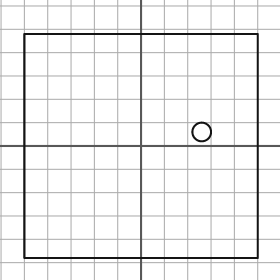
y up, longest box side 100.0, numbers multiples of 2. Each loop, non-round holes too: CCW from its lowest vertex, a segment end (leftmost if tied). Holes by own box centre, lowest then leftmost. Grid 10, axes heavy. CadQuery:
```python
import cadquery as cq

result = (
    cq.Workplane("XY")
    .moveTo(-50.0, -48.0)
    .lineTo(50.0, -48.0)
    .lineTo(50.0, 48.0)
    .lineTo(-50.0, 48.0)
    .close()
    .moveTo(26.0, 6.0)
    .circle(4.0)
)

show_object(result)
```